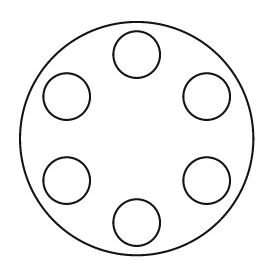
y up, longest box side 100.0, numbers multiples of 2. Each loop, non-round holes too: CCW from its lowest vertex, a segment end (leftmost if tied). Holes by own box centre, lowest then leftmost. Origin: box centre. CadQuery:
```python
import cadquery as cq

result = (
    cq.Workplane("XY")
    .moveTo(0.0, 0.0)
    .circle(50.0)
    .moveTo(0.0, -36.0)
    .circle(10.0)
    .moveTo(-30.0, -18.0)
    .circle(10.0)
    .moveTo(30.0, -18.0)
    .circle(10.0)
    .moveTo(-30.0, 18.0)
    .circle(10.0)
    .moveTo(30.0, 18.0)
    .circle(10.0)
    .moveTo(0.0, 36.0)
    .circle(10.0)
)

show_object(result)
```